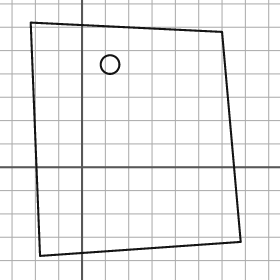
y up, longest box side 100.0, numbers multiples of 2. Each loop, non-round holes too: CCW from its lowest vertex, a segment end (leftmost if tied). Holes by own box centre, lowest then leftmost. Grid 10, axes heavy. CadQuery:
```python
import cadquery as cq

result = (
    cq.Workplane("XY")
    .moveTo(-18.0, -38.0)
    .lineTo(68.0, -32.0)
    .lineTo(60.0, 58.0)
    .lineTo(-22.0, 62.0)
    .close()
    .moveTo(12.0, 44.0)
    .circle(4.0)
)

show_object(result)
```